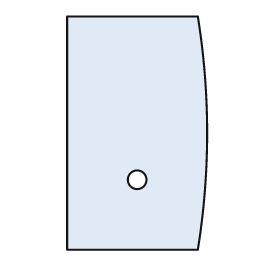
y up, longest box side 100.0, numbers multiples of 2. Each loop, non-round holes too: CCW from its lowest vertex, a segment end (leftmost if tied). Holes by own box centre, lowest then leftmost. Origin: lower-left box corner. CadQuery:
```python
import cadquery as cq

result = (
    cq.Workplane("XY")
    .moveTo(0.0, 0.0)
    .lineTo(56.0, 0.0)
    .threePointArc((60.0, 50.0), (56.0, 100.0))
    .lineTo(0.0, 100.0)
    .close()
    .moveTo(30.0, 30.0)
    .circle(4.0)
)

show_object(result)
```